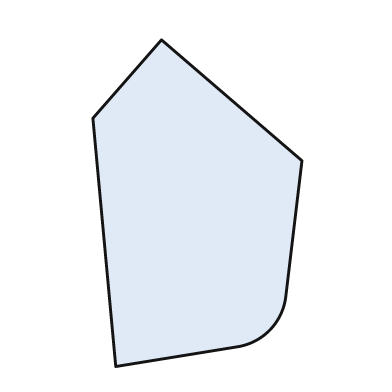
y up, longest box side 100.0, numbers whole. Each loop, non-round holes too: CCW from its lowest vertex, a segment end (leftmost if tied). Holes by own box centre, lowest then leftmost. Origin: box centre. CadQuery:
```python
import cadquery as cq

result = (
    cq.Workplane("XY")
    .moveTo(-25.0, -50.0)
    .lineTo(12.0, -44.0)
    .threePointArc((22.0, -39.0), (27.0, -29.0))
    .lineTo(32.0, 13.0)
    .lineTo(-11.0, 50.0)
    .lineTo(-32.0, 26.0)
    .close()
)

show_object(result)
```